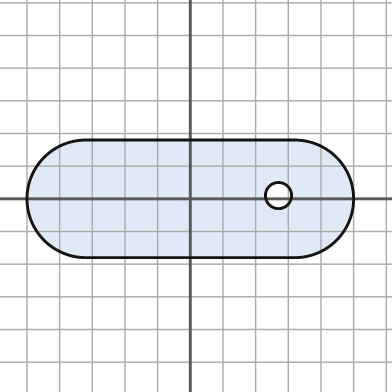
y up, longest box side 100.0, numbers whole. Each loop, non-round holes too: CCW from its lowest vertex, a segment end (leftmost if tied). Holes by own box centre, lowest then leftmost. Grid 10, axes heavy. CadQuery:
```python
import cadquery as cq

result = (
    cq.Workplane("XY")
    .moveTo(-32.0, -18.0)
    .lineTo(32.0, -18.0)
    .threePointArc((50.0, 0.0), (32.0, 18.0))
    .lineTo(-32.0, 18.0)
    .threePointArc((-50.0, 0.0), (-32.0, -18.0))
    .close()
    .moveTo(27.0, 1.0)
    .circle(4.0)
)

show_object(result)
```